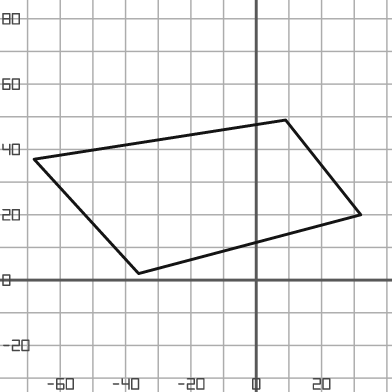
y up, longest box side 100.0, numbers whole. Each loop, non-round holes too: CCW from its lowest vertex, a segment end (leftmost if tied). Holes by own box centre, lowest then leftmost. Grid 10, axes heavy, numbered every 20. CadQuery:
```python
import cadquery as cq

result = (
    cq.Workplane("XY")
    .moveTo(-36.0, 2.0)
    .lineTo(32.0, 20.0)
    .lineTo(9.0, 49.0)
    .lineTo(-68.0, 37.0)
    .close()
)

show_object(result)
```